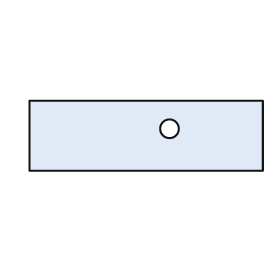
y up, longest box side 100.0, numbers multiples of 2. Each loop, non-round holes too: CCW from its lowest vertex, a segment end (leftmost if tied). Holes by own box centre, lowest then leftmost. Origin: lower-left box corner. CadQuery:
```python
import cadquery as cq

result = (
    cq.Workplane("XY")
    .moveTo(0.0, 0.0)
    .lineTo(100.0, 0.0)
    .lineTo(100.0, 30.0)
    .lineTo(0.0, 30.0)
    .close()
    .moveTo(60.0, 18.0)
    .circle(4.0)
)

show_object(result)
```